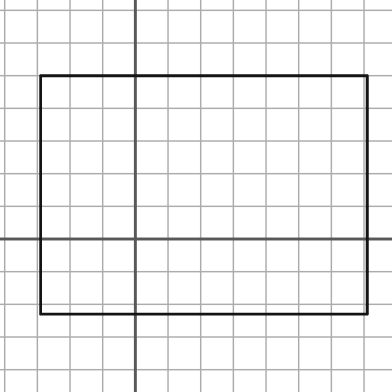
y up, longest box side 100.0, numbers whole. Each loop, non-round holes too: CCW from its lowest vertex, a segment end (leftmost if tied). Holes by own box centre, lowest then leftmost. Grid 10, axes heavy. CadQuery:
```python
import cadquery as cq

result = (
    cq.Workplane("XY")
    .moveTo(-29.0, -23.0)
    .lineTo(71.0, -23.0)
    .lineTo(71.0, 50.0)
    .lineTo(-29.0, 50.0)
    .close()
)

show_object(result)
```